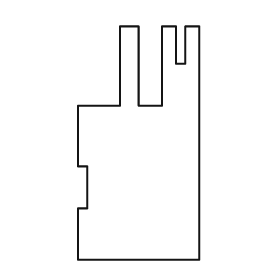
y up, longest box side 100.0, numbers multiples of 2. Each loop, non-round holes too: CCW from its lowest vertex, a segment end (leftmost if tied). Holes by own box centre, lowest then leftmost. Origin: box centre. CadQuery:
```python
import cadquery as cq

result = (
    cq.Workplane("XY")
    .moveTo(-26.0, -50.0)
    .lineTo(26.0, -50.0)
    .lineTo(26.0, 50.0)
    .lineTo(20.0, 50.0)
    .lineTo(20.0, 34.0)
    .lineTo(16.0, 34.0)
    .lineTo(16.0, 50.0)
    .lineTo(10.0, 50.0)
    .lineTo(10.0, 16.0)
    .lineTo(0.0, 16.0)
    .lineTo(0.0, 50.0)
    .lineTo(-8.0, 50.0)
    .lineTo(-8.0, 16.0)
    .lineTo(-26.0, 16.0)
    .lineTo(-26.0, -10.0)
    .lineTo(-22.0, -10.0)
    .lineTo(-22.0, -28.0)
    .lineTo(-26.0, -28.0)
    .close()
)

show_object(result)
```